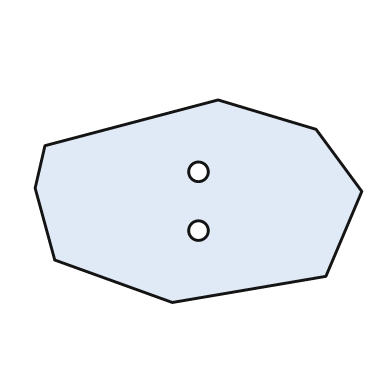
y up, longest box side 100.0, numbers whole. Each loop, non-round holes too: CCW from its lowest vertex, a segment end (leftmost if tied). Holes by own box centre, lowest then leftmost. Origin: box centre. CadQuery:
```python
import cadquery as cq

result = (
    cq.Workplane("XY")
    .moveTo(-8.0, -31.0)
    .lineTo(39.0, -23.0)
    .lineTo(50.0, 3.0)
    .lineTo(36.0, 22.0)
    .lineTo(6.0, 31.0)
    .lineTo(-47.0, 17.0)
    .lineTo(-50.0, 4.0)
    .lineTo(-44.0, -18.0)
    .close()
    .moveTo(0.0, -9.0)
    .circle(3.0)
    .moveTo(0.0, 9.0)
    .circle(3.0)
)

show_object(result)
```